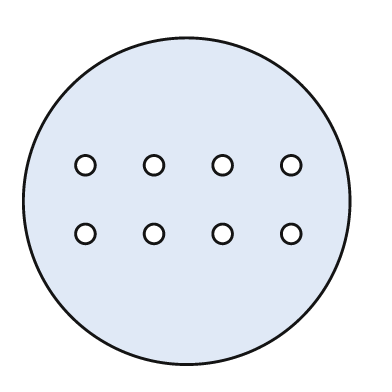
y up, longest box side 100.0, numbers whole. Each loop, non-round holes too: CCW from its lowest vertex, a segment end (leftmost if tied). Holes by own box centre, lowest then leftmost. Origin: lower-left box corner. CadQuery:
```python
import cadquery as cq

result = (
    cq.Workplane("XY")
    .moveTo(50.0, 50.0)
    .circle(50.0)
    .moveTo(19.0, 40.0)
    .circle(3.0)
    .moveTo(40.0, 40.0)
    .circle(3.0)
    .moveTo(61.0, 40.0)
    .circle(3.0)
    .moveTo(82.0, 40.0)
    .circle(3.0)
    .moveTo(19.0, 61.0)
    .circle(3.0)
    .moveTo(40.0, 61.0)
    .circle(3.0)
    .moveTo(61.0, 61.0)
    .circle(3.0)
    .moveTo(82.0, 61.0)
    .circle(3.0)
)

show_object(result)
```